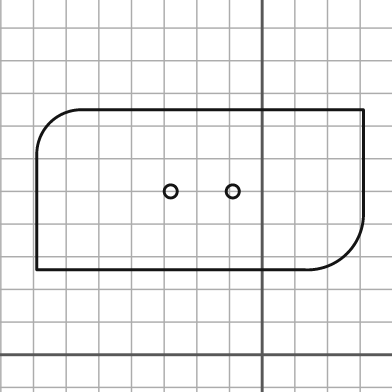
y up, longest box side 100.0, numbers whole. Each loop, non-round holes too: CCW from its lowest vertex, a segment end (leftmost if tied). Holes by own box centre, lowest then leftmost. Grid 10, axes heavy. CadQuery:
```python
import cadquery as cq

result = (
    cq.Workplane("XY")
    .moveTo(-69.0, 26.0)
    .lineTo(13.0, 26.0)
    .threePointArc((26.0, 31.0), (31.0, 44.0))
    .lineTo(31.0, 75.0)
    .lineTo(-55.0, 75.0)
    .threePointArc((-65.0, 71.0), (-69.0, 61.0))
    .close()
    .moveTo(-28.0, 50.0)
    .circle(2.0)
    .moveTo(-9.0, 50.0)
    .circle(2.0)
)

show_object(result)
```